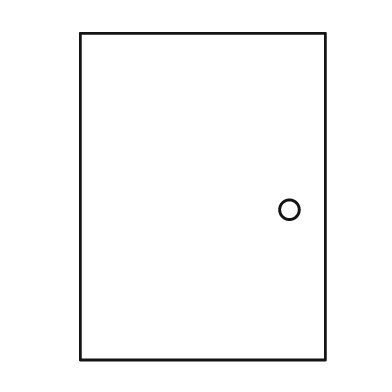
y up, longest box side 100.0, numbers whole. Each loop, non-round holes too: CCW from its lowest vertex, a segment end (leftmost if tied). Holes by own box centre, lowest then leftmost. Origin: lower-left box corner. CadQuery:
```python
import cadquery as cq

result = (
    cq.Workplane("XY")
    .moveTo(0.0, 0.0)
    .lineTo(75.0, 0.0)
    .lineTo(75.0, 100.0)
    .lineTo(0.0, 100.0)
    .close()
    .moveTo(64.0, 46.0)
    .circle(3.0)
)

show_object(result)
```